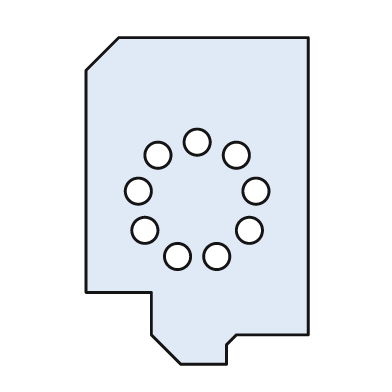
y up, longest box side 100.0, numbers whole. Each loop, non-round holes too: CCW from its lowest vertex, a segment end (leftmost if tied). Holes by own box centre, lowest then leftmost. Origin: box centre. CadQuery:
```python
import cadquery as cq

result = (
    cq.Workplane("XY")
    .moveTo(-5.0, -50.0)
    .lineTo(9.0, -50.0)
    .lineTo(9.0, -44.0)
    .lineTo(12.0, -41.0)
    .lineTo(34.0, -41.0)
    .lineTo(34.0, 50.0)
    .lineTo(-24.0, 50.0)
    .lineTo(-34.0, 40.0)
    .lineTo(-34.0, -28.0)
    .lineTo(-14.0, -28.0)
    .lineTo(-14.0, -41.0)
    .close()
    .moveTo(-6.0, -17.0)
    .circle(4.0)
    .moveTo(6.0, -17.0)
    .circle(4.0)
    .moveTo(-16.0, -9.0)
    .circle(4.0)
    .moveTo(16.0, -9.0)
    .circle(4.0)
    .moveTo(-18.0, 3.0)
    .circle(4.0)
    .moveTo(18.0, 3.0)
    .circle(4.0)
    .moveTo(-12.0, 14.0)
    .circle(4.0)
    .moveTo(12.0, 14.0)
    .circle(4.0)
    .moveTo(0.0, 18.0)
    .circle(4.0)
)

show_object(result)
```